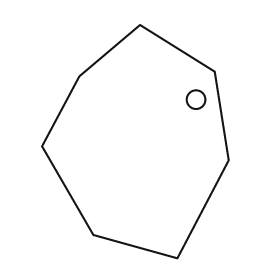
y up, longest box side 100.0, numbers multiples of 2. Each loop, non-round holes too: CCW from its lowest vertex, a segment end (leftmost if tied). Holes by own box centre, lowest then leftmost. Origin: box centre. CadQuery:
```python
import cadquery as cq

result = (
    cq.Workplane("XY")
    .moveTo(18.0, -50.0)
    .lineTo(40.0, -8.0)
    .lineTo(34.0, 30.0)
    .lineTo(2.0, 50.0)
    .lineTo(-24.0, 28.0)
    .lineTo(-40.0, -2.0)
    .lineTo(-18.0, -40.0)
    .close()
    .moveTo(26.0, 18.0)
    .circle(4.0)
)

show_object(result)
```